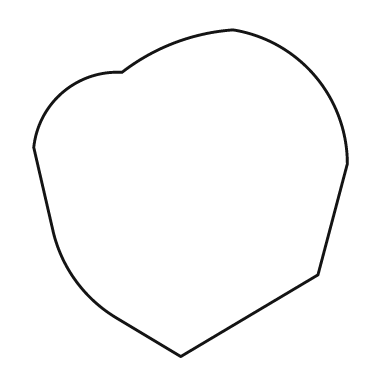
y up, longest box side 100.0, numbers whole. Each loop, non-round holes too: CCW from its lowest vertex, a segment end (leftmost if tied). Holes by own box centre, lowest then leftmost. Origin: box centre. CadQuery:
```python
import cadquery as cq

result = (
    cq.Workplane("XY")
    .moveTo(-3.0, -50.0)
    .lineTo(39.0, -25.0)
    .lineTo(48.0, 9.0)
    .threePointArc((38.0, 36.0), (13.0, 50.0))
    .threePointArc((-5.0, 46.0), (-21.0, 37.0))
    .threePointArc((-39.0, 31.0), (-48.0, 14.0))
    .lineTo(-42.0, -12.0)
    .threePointArc((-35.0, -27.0), (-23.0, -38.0))
    .close()
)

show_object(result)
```